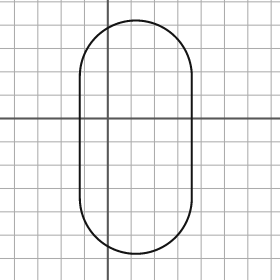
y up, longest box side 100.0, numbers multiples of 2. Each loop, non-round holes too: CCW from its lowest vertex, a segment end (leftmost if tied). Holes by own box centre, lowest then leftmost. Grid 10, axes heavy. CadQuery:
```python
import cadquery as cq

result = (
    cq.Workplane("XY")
    .moveTo(-12.0, -34.0)
    .threePointArc((12.0, -58.0), (36.0, -34.0))
    .lineTo(36.0, 18.0)
    .threePointArc((12.0, 42.0), (-12.0, 18.0))
    .close()
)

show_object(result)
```